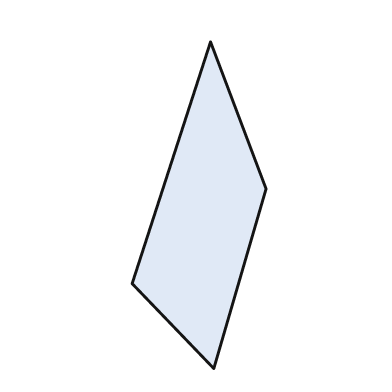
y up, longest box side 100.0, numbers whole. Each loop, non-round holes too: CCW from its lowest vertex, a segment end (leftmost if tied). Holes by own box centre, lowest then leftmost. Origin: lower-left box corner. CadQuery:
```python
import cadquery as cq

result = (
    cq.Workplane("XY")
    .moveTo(25.0, 0.0)
    .lineTo(41.0, 55.0)
    .lineTo(24.0, 100.0)
    .lineTo(0.0, 26.0)
    .close()
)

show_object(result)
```